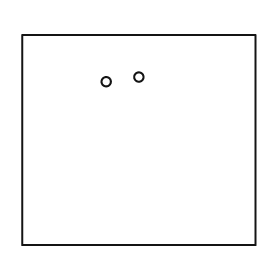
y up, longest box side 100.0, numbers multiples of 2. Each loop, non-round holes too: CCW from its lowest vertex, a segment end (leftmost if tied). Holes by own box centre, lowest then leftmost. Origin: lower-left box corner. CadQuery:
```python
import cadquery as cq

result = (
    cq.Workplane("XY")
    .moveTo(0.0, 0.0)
    .lineTo(100.0, 0.0)
    .lineTo(100.0, 90.0)
    .lineTo(0.0, 90.0)
    .close()
    .moveTo(36.0, 70.0)
    .circle(2.0)
    .moveTo(50.0, 72.0)
    .circle(2.0)
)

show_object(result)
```